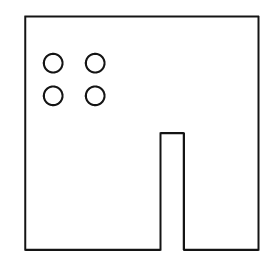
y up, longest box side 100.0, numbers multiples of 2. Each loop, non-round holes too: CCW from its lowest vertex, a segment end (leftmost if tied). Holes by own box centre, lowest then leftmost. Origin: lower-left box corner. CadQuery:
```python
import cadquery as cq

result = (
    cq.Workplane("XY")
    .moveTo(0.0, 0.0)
    .lineTo(58.0, 0.0)
    .lineTo(58.0, 50.0)
    .lineTo(68.0, 50.0)
    .lineTo(68.0, 0.0)
    .lineTo(100.0, 0.0)
    .lineTo(100.0, 100.0)
    .lineTo(0.0, 100.0)
    .close()
    .moveTo(12.0, 66.0)
    .circle(4.0)
    .moveTo(30.0, 66.0)
    .circle(4.0)
    .moveTo(12.0, 80.0)
    .circle(4.0)
    .moveTo(30.0, 80.0)
    .circle(4.0)
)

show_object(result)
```